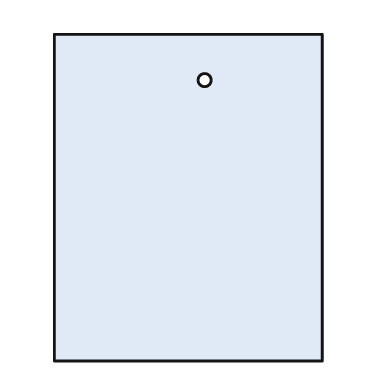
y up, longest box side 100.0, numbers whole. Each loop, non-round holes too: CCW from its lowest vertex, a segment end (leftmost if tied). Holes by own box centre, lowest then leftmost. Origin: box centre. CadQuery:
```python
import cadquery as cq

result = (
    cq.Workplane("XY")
    .moveTo(-41.0, -50.0)
    .lineTo(41.0, -50.0)
    .lineTo(41.0, 50.0)
    .lineTo(-41.0, 50.0)
    .close()
    .moveTo(5.0, 36.0)
    .circle(2.0)
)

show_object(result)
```